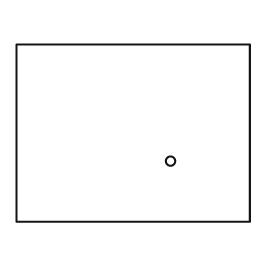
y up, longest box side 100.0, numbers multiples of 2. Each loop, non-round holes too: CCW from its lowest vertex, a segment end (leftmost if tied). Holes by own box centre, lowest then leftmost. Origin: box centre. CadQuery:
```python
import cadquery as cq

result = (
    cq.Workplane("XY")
    .moveTo(-50.0, -38.0)
    .lineTo(50.0, -38.0)
    .lineTo(50.0, 38.0)
    .lineTo(-50.0, 38.0)
    .close()
    .moveTo(16.0, -12.0)
    .circle(2.0)
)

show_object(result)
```